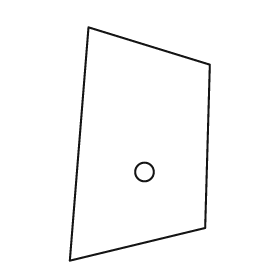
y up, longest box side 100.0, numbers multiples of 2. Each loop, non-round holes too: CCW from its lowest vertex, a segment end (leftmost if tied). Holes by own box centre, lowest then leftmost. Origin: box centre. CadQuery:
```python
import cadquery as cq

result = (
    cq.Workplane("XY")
    .moveTo(-30.0, -50.0)
    .lineTo(28.0, -36.0)
    .lineTo(30.0, 34.0)
    .lineTo(-22.0, 50.0)
    .close()
    .moveTo(2.0, -12.0)
    .circle(4.0)
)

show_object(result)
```